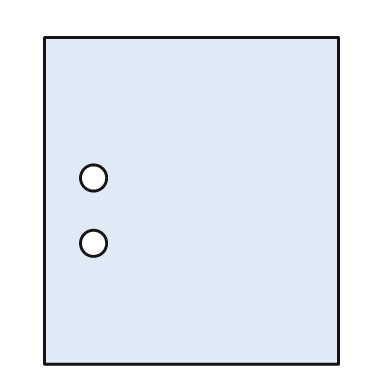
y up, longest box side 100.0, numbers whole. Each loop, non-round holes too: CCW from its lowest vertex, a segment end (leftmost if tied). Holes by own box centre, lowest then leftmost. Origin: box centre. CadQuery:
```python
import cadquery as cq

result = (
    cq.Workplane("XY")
    .moveTo(-45.0, -50.0)
    .lineTo(45.0, -50.0)
    .lineTo(45.0, 50.0)
    .lineTo(-45.0, 50.0)
    .close()
    .moveTo(-30.0, -13.0)
    .circle(4.0)
    .moveTo(-30.0, 7.0)
    .circle(4.0)
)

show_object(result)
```